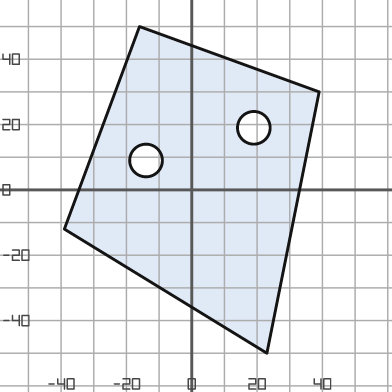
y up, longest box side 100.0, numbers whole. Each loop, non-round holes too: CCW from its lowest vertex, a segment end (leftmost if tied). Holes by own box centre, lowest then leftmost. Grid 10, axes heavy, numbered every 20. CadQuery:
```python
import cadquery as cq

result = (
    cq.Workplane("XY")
    .moveTo(23.0, -50.0)
    .lineTo(39.0, 30.0)
    .lineTo(-16.0, 50.0)
    .lineTo(-39.0, -12.0)
    .close()
    .moveTo(-14.0, 9.0)
    .circle(5.0)
    .moveTo(19.0, 19.0)
    .circle(5.0)
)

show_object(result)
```